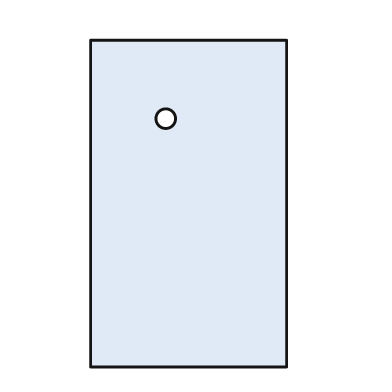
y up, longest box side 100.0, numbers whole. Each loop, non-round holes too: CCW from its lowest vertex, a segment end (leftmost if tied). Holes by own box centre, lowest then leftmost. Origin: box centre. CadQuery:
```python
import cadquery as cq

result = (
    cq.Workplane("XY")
    .moveTo(-30.0, -50.0)
    .lineTo(30.0, -50.0)
    .lineTo(30.0, 50.0)
    .lineTo(-30.0, 50.0)
    .close()
    .moveTo(-7.0, 26.0)
    .circle(3.0)
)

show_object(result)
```